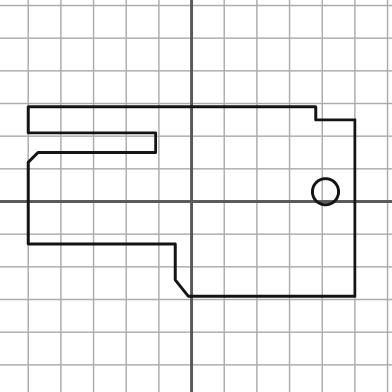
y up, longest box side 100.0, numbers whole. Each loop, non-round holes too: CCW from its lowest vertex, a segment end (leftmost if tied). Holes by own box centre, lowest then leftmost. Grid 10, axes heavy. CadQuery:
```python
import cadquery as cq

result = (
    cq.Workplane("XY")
    .moveTo(-1.0, -29.0)
    .lineTo(50.0, -29.0)
    .lineTo(50.0, 25.0)
    .lineTo(38.0, 25.0)
    .lineTo(38.0, 29.0)
    .lineTo(-50.0, 29.0)
    .lineTo(-50.0, 21.0)
    .lineTo(-11.0, 21.0)
    .lineTo(-11.0, 15.0)
    .lineTo(-47.0, 15.0)
    .lineTo(-50.0, 12.0)
    .lineTo(-50.0, -13.0)
    .lineTo(-5.0, -13.0)
    .lineTo(-5.0, -24.0)
    .close()
    .moveTo(41.0, 3.0)
    .circle(4.0)
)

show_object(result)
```